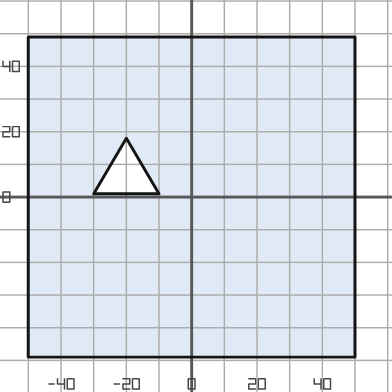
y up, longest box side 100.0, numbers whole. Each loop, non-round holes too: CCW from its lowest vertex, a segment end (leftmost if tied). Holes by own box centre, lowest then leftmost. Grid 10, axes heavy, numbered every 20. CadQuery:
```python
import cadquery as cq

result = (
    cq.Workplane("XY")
    .moveTo(-50.0, -49.0)
    .lineTo(50.0, -49.0)
    .lineTo(50.0, 49.0)
    .lineTo(-50.0, 49.0)
    .close()
    .moveTo(-30.0, 1.0)
    .lineTo(-10.0, 1.0)
    .lineTo(-20.0, 18.0)
    .close()
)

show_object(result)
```